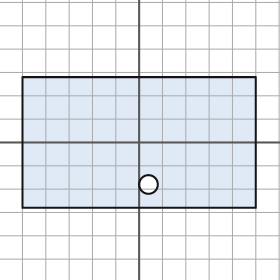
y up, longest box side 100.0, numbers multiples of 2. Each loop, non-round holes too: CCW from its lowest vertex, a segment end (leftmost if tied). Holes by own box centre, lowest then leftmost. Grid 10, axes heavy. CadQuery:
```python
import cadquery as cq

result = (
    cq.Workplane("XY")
    .moveTo(-50.0, -28.0)
    .lineTo(50.0, -28.0)
    .lineTo(50.0, 28.0)
    .lineTo(-50.0, 28.0)
    .close()
    .moveTo(4.0, -18.0)
    .circle(4.0)
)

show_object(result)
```